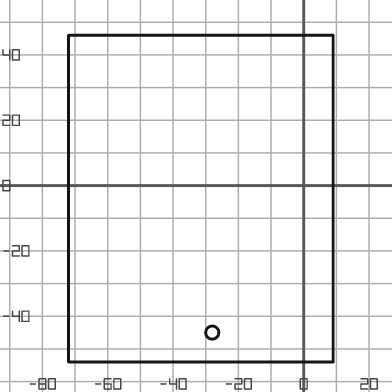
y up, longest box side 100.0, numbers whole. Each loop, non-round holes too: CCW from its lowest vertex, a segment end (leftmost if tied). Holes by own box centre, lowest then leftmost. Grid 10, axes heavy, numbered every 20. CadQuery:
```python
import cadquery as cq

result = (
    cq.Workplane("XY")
    .moveTo(-72.0, -54.0)
    .lineTo(9.0, -54.0)
    .lineTo(9.0, 46.0)
    .lineTo(-72.0, 46.0)
    .close()
    .moveTo(-28.0, -45.0)
    .circle(2.0)
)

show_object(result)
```